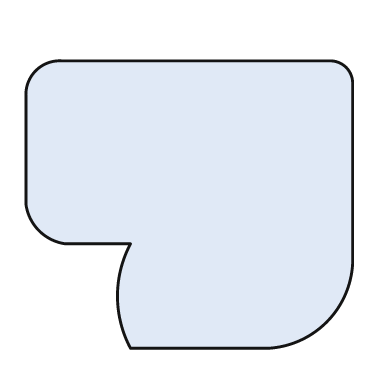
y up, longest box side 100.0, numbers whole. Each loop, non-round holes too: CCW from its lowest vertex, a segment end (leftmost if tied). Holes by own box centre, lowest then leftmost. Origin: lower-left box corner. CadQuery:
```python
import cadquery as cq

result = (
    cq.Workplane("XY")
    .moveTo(32.0, 0.0)
    .lineTo(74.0, 0.0)
    .threePointArc((92.0, 8.0), (100.0, 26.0))
    .lineTo(100.0, 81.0)
    .threePointArc((98.0, 86.0), (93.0, 88.0))
    .lineTo(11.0, 88.0)
    .threePointArc((3.0, 85.0), (0.0, 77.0))
    .lineTo(0.0, 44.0)
    .threePointArc((4.0, 36.0), (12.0, 32.0))
    .lineTo(32.0, 32.0)
    .threePointArc((28.0, 16.0), (32.0, 0.0))
    .close()
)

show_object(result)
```